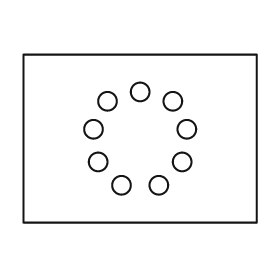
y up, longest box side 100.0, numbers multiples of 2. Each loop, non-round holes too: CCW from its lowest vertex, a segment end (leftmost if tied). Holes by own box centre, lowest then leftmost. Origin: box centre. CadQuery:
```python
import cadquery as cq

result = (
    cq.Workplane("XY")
    .moveTo(-50.0, -36.0)
    .lineTo(50.0, -36.0)
    .lineTo(50.0, 36.0)
    .lineTo(-50.0, 36.0)
    .close()
    .moveTo(-8.0, -20.0)
    .circle(4.0)
    .moveTo(8.0, -20.0)
    .circle(4.0)
    .moveTo(-18.0, -10.0)
    .circle(4.0)
    .moveTo(18.0, -10.0)
    .circle(4.0)
    .moveTo(-20.0, 4.0)
    .circle(4.0)
    .moveTo(20.0, 4.0)
    .circle(4.0)
    .moveTo(-14.0, 16.0)
    .circle(4.0)
    .moveTo(14.0, 16.0)
    .circle(4.0)
    .moveTo(0.0, 20.0)
    .circle(4.0)
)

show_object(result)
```